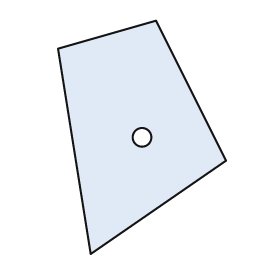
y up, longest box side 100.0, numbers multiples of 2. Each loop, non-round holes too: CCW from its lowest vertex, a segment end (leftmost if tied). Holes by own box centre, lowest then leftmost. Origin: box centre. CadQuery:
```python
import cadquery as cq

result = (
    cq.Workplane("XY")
    .moveTo(-22.0, -50.0)
    .lineTo(36.0, -10.0)
    .lineTo(6.0, 50.0)
    .lineTo(-36.0, 38.0)
    .close()
    .moveTo(0.0, 0.0)
    .circle(4.0)
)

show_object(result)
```